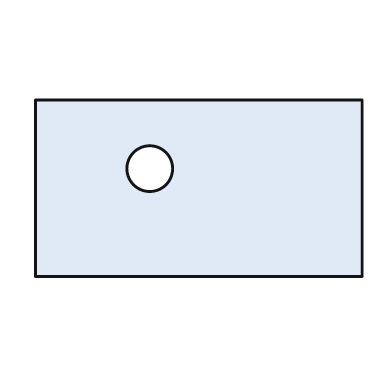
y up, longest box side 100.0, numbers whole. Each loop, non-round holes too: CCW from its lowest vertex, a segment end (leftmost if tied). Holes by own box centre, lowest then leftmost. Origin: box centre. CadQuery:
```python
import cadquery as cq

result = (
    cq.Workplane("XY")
    .moveTo(-50.0, -27.0)
    .lineTo(50.0, -27.0)
    .lineTo(50.0, 27.0)
    .lineTo(-50.0, 27.0)
    .close()
    .moveTo(-15.0, 6.0)
    .circle(7.0)
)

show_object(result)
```